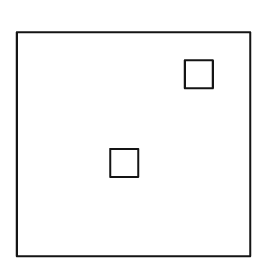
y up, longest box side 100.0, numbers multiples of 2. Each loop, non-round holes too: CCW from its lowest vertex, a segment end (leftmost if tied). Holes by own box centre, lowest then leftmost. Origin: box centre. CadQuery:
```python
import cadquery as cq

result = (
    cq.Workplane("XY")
    .moveTo(-50.0, -48.0)
    .lineTo(50.0, -48.0)
    .lineTo(50.0, 48.0)
    .lineTo(-50.0, 48.0)
    .close()
    .moveTo(-10.0, -14.0)
    .lineTo(2.0, -14.0)
    .lineTo(2.0, -2.0)
    .lineTo(-10.0, -2.0)
    .close()
    .moveTo(22.0, 24.0)
    .lineTo(34.0, 24.0)
    .lineTo(34.0, 36.0)
    .lineTo(22.0, 36.0)
    .close()
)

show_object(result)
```